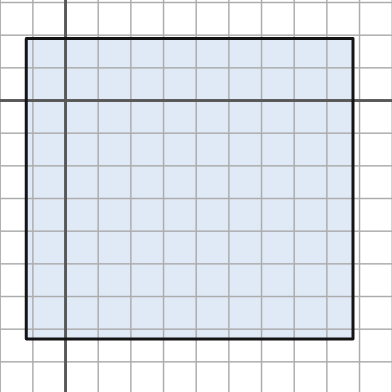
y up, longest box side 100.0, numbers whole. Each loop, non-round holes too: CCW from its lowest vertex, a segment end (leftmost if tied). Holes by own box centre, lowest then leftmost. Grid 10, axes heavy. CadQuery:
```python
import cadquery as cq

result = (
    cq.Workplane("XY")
    .moveTo(-12.0, -73.0)
    .lineTo(88.0, -73.0)
    .lineTo(88.0, 19.0)
    .lineTo(-12.0, 19.0)
    .close()
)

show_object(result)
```